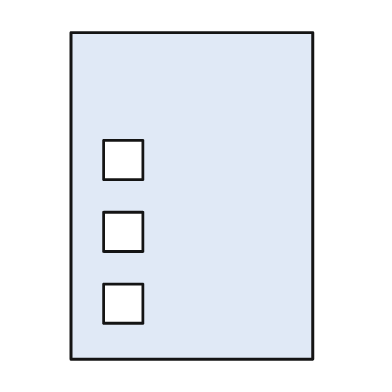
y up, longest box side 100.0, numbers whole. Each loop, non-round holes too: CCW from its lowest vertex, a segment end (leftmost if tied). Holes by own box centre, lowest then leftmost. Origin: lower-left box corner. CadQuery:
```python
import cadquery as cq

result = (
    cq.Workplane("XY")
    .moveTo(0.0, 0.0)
    .lineTo(74.0, 0.0)
    .lineTo(74.0, 100.0)
    .lineTo(0.0, 100.0)
    .close()
    .moveTo(10.0, 11.0)
    .lineTo(22.0, 11.0)
    .lineTo(22.0, 23.0)
    .lineTo(10.0, 23.0)
    .close()
    .moveTo(10.0, 33.0)
    .lineTo(22.0, 33.0)
    .lineTo(22.0, 45.0)
    .lineTo(10.0, 45.0)
    .close()
    .moveTo(10.0, 55.0)
    .lineTo(22.0, 55.0)
    .lineTo(22.0, 67.0)
    .lineTo(10.0, 67.0)
    .close()
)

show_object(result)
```